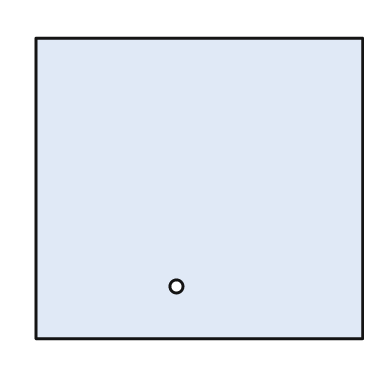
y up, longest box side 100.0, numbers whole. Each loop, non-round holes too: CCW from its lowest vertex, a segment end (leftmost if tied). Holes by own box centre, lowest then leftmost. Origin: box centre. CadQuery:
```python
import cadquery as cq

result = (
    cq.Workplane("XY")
    .moveTo(-50.0, -46.0)
    .lineTo(50.0, -46.0)
    .lineTo(50.0, 46.0)
    .lineTo(-50.0, 46.0)
    .close()
    .moveTo(-7.0, -30.0)
    .circle(2.0)
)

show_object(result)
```